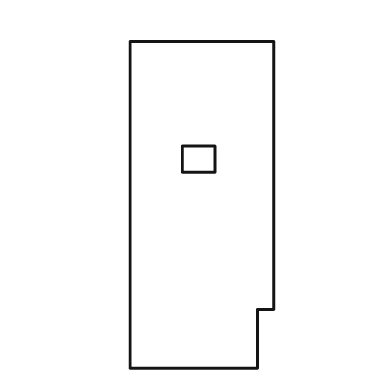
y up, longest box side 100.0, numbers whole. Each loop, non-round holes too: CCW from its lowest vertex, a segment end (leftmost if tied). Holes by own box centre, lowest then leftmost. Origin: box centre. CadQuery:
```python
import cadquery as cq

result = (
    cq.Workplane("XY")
    .moveTo(-22.0, -50.0)
    .lineTo(17.0, -50.0)
    .lineTo(17.0, -32.0)
    .lineTo(22.0, -32.0)
    .lineTo(22.0, 50.0)
    .lineTo(-22.0, 50.0)
    .close()
    .moveTo(-6.0, 10.0)
    .lineTo(4.0, 10.0)
    .lineTo(4.0, 18.0)
    .lineTo(-6.0, 18.0)
    .close()
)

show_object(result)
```